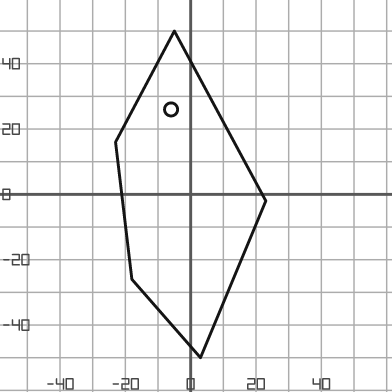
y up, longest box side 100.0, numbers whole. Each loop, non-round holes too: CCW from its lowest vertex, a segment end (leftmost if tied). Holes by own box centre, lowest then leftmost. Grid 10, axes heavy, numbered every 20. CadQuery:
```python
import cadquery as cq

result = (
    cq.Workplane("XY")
    .moveTo(3.0, -50.0)
    .lineTo(23.0, -2.0)
    .lineTo(-5.0, 50.0)
    .lineTo(-23.0, 16.0)
    .lineTo(-18.0, -26.0)
    .close()
    .moveTo(-6.0, 26.0)
    .circle(2.0)
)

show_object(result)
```